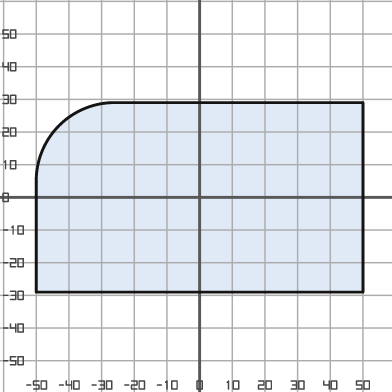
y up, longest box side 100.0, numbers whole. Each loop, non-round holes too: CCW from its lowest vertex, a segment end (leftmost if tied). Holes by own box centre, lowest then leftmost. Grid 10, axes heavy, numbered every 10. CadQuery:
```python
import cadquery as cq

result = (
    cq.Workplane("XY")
    .moveTo(-50.0, -29.0)
    .lineTo(50.0, -29.0)
    .lineTo(50.0, 29.0)
    .lineTo(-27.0, 29.0)
    .threePointArc((-43.0, 22.0), (-50.0, 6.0))
    .close()
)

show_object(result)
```